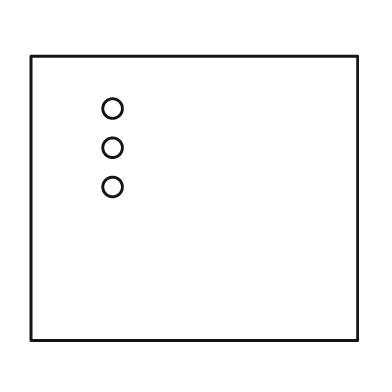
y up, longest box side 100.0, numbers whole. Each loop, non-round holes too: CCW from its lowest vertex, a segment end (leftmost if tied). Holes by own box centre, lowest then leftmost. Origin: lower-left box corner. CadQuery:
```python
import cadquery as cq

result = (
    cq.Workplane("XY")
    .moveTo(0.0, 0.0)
    .lineTo(100.0, 0.0)
    .lineTo(100.0, 87.0)
    .lineTo(0.0, 87.0)
    .close()
    .moveTo(25.0, 47.0)
    .circle(3.0)
    .moveTo(25.0, 59.0)
    .circle(3.0)
    .moveTo(25.0, 71.0)
    .circle(3.0)
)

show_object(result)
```